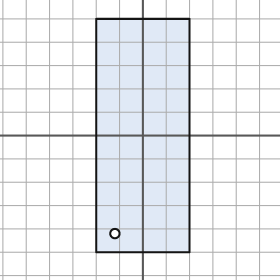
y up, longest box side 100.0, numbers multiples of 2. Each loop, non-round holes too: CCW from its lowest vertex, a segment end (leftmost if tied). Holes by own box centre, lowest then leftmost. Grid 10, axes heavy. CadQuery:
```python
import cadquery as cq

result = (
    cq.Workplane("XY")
    .moveTo(-20.0, -50.0)
    .lineTo(20.0, -50.0)
    .lineTo(20.0, 50.0)
    .lineTo(-20.0, 50.0)
    .close()
    .moveTo(-12.0, -42.0)
    .circle(2.0)
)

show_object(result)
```